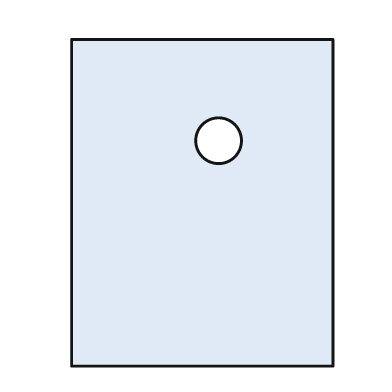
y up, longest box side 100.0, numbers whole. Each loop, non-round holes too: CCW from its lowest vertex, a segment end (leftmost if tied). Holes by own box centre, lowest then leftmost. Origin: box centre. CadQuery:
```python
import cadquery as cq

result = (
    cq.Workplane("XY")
    .moveTo(-40.0, -50.0)
    .lineTo(40.0, -50.0)
    .lineTo(40.0, 50.0)
    .lineTo(-40.0, 50.0)
    .close()
    .moveTo(5.0, 19.0)
    .circle(7.0)
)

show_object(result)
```